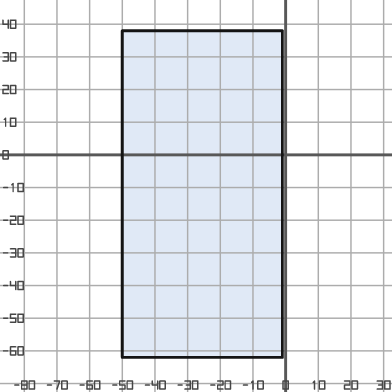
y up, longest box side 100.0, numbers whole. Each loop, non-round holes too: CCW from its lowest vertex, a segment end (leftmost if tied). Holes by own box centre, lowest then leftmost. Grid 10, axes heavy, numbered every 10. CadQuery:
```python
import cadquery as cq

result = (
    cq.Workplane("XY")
    .moveTo(-50.0, -62.0)
    .lineTo(-1.0, -62.0)
    .lineTo(-1.0, 38.0)
    .lineTo(-50.0, 38.0)
    .close()
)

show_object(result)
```